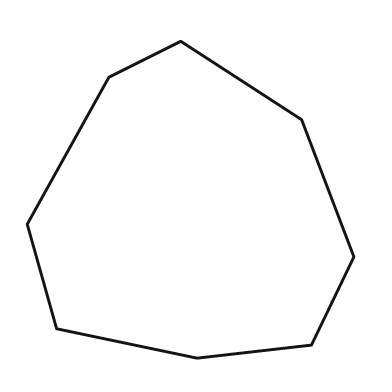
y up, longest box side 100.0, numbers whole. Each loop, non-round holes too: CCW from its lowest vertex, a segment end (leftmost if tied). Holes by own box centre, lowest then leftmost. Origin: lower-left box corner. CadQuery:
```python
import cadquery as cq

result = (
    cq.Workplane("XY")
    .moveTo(52.0, 0.0)
    .lineTo(87.0, 4.0)
    .lineTo(100.0, 31.0)
    .lineTo(84.0, 73.0)
    .lineTo(47.0, 97.0)
    .lineTo(25.0, 86.0)
    .lineTo(0.0, 41.0)
    .lineTo(9.0, 9.0)
    .close()
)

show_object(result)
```